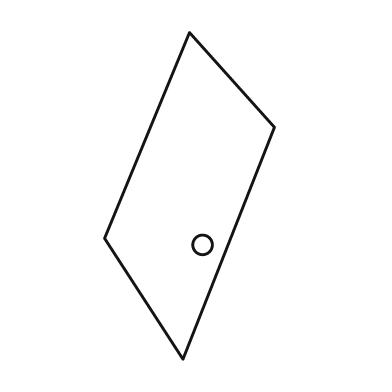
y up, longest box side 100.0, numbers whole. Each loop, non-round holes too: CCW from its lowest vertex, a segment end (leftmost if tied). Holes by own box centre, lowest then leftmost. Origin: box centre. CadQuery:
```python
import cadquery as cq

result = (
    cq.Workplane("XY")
    .moveTo(-2.0, -50.0)
    .lineTo(26.0, 21.0)
    .lineTo(0.0, 50.0)
    .lineTo(-26.0, -13.0)
    .close()
    .moveTo(4.0, -15.0)
    .circle(3.0)
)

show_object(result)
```